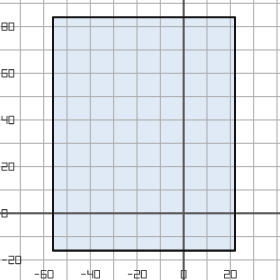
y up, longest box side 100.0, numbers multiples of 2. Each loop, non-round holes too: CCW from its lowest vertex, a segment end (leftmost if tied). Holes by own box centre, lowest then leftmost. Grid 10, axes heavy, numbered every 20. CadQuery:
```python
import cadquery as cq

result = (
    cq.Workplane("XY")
    .moveTo(-56.0, -16.0)
    .lineTo(22.0, -16.0)
    .lineTo(22.0, 84.0)
    .lineTo(-56.0, 84.0)
    .close()
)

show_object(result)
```